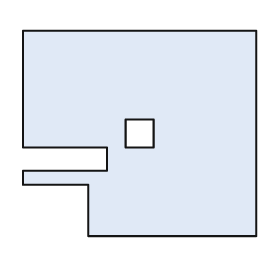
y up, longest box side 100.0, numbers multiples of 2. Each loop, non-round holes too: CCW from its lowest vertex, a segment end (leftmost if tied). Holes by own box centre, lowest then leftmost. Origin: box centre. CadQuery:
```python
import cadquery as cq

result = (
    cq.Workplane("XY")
    .moveTo(-22.0, -44.0)
    .lineTo(50.0, -44.0)
    .lineTo(50.0, 44.0)
    .lineTo(-50.0, 44.0)
    .lineTo(-50.0, -6.0)
    .lineTo(-14.0, -6.0)
    .lineTo(-14.0, -16.0)
    .lineTo(-50.0, -16.0)
    .lineTo(-50.0, -22.0)
    .lineTo(-22.0, -22.0)
    .close()
    .moveTo(-6.0, -6.0)
    .lineTo(6.0, -6.0)
    .lineTo(6.0, 6.0)
    .lineTo(-6.0, 6.0)
    .close()
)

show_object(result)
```